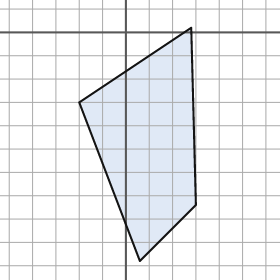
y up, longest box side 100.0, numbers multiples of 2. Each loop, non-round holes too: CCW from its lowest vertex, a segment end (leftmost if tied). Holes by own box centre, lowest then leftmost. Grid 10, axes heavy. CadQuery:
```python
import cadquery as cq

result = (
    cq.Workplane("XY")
    .moveTo(6.0, -98.0)
    .lineTo(30.0, -74.0)
    .lineTo(28.0, 2.0)
    .lineTo(-20.0, -30.0)
    .close()
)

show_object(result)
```